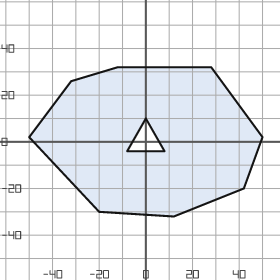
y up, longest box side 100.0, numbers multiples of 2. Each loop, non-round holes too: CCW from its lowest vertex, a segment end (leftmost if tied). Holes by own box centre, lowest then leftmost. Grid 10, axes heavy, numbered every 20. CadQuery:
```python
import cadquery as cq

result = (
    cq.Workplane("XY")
    .moveTo(12.0, -32.0)
    .lineTo(42.0, -20.0)
    .lineTo(50.0, 2.0)
    .lineTo(28.0, 32.0)
    .lineTo(-12.0, 32.0)
    .lineTo(-32.0, 26.0)
    .lineTo(-50.0, 2.0)
    .lineTo(-20.0, -30.0)
    .close()
    .moveTo(-8.0, -4.0)
    .lineTo(8.0, -4.0)
    .lineTo(0.0, 10.0)
    .close()
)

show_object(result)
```